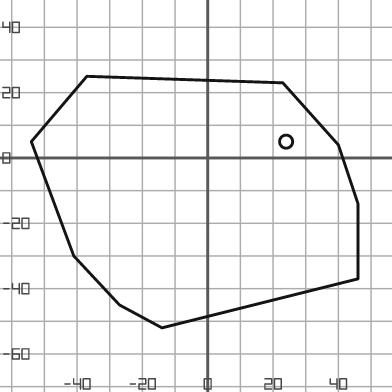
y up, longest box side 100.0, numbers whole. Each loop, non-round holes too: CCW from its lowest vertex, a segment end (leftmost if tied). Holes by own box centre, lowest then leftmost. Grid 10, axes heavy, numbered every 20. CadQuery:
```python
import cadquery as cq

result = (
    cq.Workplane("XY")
    .moveTo(-14.0, -52.0)
    .lineTo(46.0, -37.0)
    .lineTo(46.0, -14.0)
    .lineTo(40.0, 4.0)
    .lineTo(23.0, 23.0)
    .lineTo(-37.0, 25.0)
    .lineTo(-54.0, 5.0)
    .lineTo(-41.0, -30.0)
    .lineTo(-27.0, -45.0)
    .close()
    .moveTo(24.0, 5.0)
    .circle(2.0)
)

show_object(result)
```